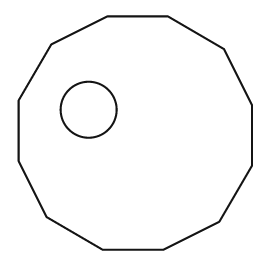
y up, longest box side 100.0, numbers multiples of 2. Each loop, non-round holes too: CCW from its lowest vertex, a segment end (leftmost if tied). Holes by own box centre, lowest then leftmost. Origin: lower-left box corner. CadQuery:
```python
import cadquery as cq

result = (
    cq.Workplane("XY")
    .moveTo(36.0, 0.0)
    .lineTo(62.0, 0.0)
    .lineTo(86.0, 12.0)
    .lineTo(100.0, 36.0)
    .lineTo(100.0, 62.0)
    .lineTo(88.0, 86.0)
    .lineTo(64.0, 100.0)
    .lineTo(38.0, 100.0)
    .lineTo(14.0, 88.0)
    .lineTo(0.0, 64.0)
    .lineTo(0.0, 38.0)
    .lineTo(12.0, 14.0)
    .close()
    .moveTo(30.0, 60.0)
    .circle(12.0)
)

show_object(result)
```